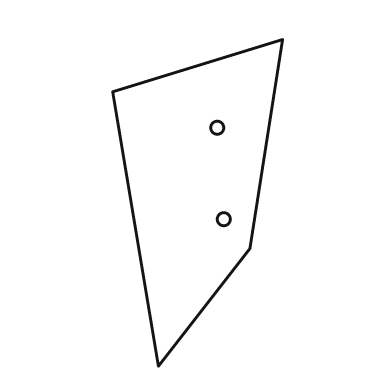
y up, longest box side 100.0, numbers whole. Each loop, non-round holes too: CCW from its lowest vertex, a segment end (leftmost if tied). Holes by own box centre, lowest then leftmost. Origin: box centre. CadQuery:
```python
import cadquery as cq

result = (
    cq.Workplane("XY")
    .moveTo(-12.0, -50.0)
    .lineTo(16.0, -14.0)
    .lineTo(26.0, 50.0)
    .lineTo(-26.0, 34.0)
    .close()
    .moveTo(8.0, -5.0)
    .circle(2.0)
    .moveTo(6.0, 23.0)
    .circle(2.0)
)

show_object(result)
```